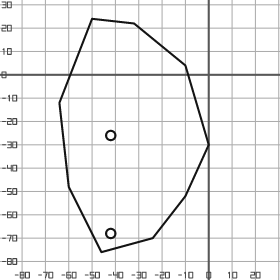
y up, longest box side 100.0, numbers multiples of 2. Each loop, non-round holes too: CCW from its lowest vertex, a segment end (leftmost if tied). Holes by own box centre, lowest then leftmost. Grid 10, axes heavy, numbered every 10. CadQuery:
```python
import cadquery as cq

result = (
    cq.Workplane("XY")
    .moveTo(-46.0, -76.0)
    .lineTo(-24.0, -70.0)
    .lineTo(-10.0, -52.0)
    .lineTo(0.0, -30.0)
    .lineTo(-10.0, 4.0)
    .lineTo(-32.0, 22.0)
    .lineTo(-50.0, 24.0)
    .lineTo(-64.0, -12.0)
    .lineTo(-60.0, -48.0)
    .close()
    .moveTo(-42.0, -68.0)
    .circle(2.0)
    .moveTo(-42.0, -26.0)
    .circle(2.0)
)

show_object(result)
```